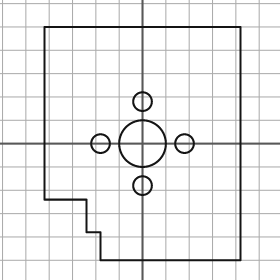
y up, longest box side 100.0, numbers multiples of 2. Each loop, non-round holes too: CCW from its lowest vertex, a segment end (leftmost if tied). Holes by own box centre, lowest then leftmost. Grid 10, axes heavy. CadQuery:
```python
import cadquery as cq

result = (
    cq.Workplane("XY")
    .moveTo(-18.0, -50.0)
    .lineTo(42.0, -50.0)
    .lineTo(42.0, 50.0)
    .lineTo(-42.0, 50.0)
    .lineTo(-42.0, -24.0)
    .lineTo(-24.0, -24.0)
    .lineTo(-24.0, -38.0)
    .lineTo(-18.0, -38.0)
    .close()
    .moveTo(0.0, -18.0)
    .circle(4.0)
    .moveTo(-18.0, 0.0)
    .circle(4.0)
    .moveTo(0.0, 0.0)
    .circle(10.0)
    .moveTo(18.0, 0.0)
    .circle(4.0)
    .moveTo(0.0, 18.0)
    .circle(4.0)
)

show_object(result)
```